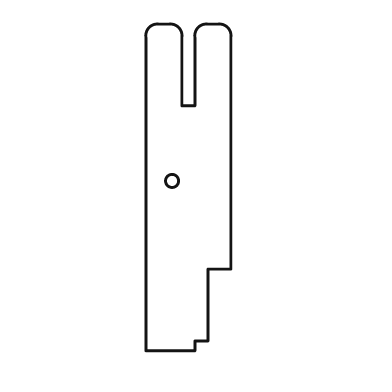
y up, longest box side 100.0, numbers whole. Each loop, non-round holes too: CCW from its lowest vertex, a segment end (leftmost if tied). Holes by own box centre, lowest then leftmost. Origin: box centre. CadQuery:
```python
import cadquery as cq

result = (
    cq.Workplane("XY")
    .moveTo(-13.0, -50.0)
    .lineTo(2.0, -50.0)
    .lineTo(2.0, -47.0)
    .lineTo(6.0, -47.0)
    .lineTo(6.0, -25.0)
    .lineTo(13.0, -25.0)
    .lineTo(13.0, 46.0)
    .threePointArc((12.0, 49.0), (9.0, 50.0))
    .lineTo(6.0, 50.0)
    .threePointArc((3.0, 49.0), (2.0, 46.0))
    .lineTo(2.0, 25.0)
    .lineTo(-2.0, 25.0)
    .lineTo(-2.0, 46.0)
    .threePointArc((-3.0, 49.0), (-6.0, 50.0))
    .lineTo(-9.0, 50.0)
    .threePointArc((-12.0, 49.0), (-13.0, 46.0))
    .close()
    .moveTo(-5.0, 2.0)
    .circle(2.0)
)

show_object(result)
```